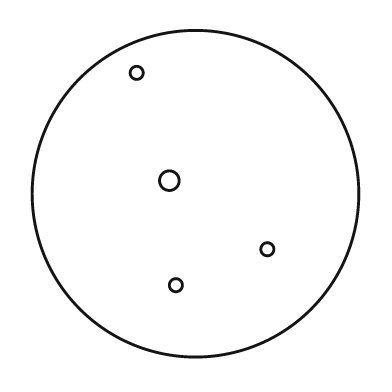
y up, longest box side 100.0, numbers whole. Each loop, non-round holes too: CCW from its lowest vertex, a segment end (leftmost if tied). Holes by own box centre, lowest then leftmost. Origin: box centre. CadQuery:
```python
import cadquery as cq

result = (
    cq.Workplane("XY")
    .moveTo(0.0, 0.0)
    .circle(50.0)
    .moveTo(-6.0, -28.0)
    .circle(2.0)
    .moveTo(22.0, -17.0)
    .circle(2.0)
    .moveTo(-8.0, 4.0)
    .circle(3.0)
    .moveTo(-18.0, 37.0)
    .circle(2.0)
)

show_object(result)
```